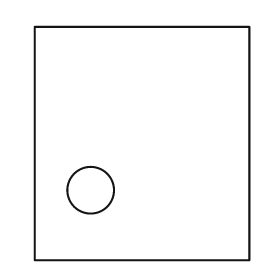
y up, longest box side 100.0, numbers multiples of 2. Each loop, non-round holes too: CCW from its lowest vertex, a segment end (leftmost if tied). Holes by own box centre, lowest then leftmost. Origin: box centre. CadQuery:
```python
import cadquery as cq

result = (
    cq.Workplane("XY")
    .moveTo(-46.0, -50.0)
    .lineTo(46.0, -50.0)
    .lineTo(46.0, 50.0)
    .lineTo(-46.0, 50.0)
    .close()
    .moveTo(-22.0, -20.0)
    .circle(10.0)
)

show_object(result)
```